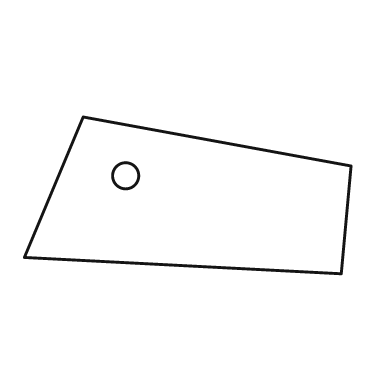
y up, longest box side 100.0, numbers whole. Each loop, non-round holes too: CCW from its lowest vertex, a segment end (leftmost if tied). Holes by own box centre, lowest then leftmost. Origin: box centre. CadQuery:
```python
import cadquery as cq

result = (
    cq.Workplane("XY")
    .moveTo(47.0, -24.0)
    .lineTo(50.0, 9.0)
    .lineTo(-32.0, 24.0)
    .lineTo(-50.0, -19.0)
    .close()
    .moveTo(-19.0, 6.0)
    .circle(4.0)
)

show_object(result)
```